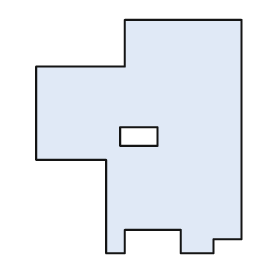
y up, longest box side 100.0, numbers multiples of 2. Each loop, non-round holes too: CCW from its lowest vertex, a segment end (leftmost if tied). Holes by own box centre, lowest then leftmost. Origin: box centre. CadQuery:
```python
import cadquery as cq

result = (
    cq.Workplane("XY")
    .moveTo(-14.0, -50.0)
    .lineTo(-6.0, -50.0)
    .lineTo(-6.0, -40.0)
    .lineTo(18.0, -40.0)
    .lineTo(18.0, -50.0)
    .lineTo(32.0, -50.0)
    .lineTo(32.0, -44.0)
    .lineTo(44.0, -44.0)
    .lineTo(44.0, 50.0)
    .lineTo(-6.0, 50.0)
    .lineTo(-6.0, 30.0)
    .lineTo(-44.0, 30.0)
    .lineTo(-44.0, -10.0)
    .lineTo(-14.0, -10.0)
    .close()
    .moveTo(-8.0, -4.0)
    .lineTo(8.0, -4.0)
    .lineTo(8.0, 4.0)
    .lineTo(-8.0, 4.0)
    .close()
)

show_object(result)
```